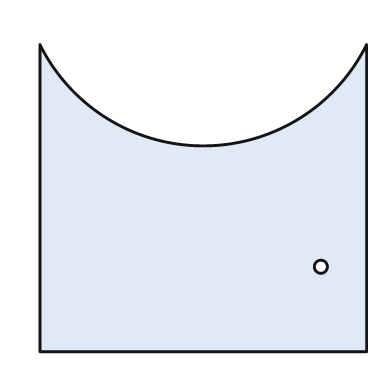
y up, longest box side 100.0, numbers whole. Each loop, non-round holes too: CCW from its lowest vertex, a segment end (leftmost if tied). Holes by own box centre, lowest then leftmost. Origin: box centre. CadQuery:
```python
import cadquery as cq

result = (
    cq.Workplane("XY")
    .moveTo(-50.0, -47.0)
    .lineTo(50.0, -47.0)
    .lineTo(50.0, 47.0)
    .threePointArc((0.0, 16.0), (-50.0, 47.0))
    .close()
    .moveTo(36.0, -21.0)
    .circle(2.0)
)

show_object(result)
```